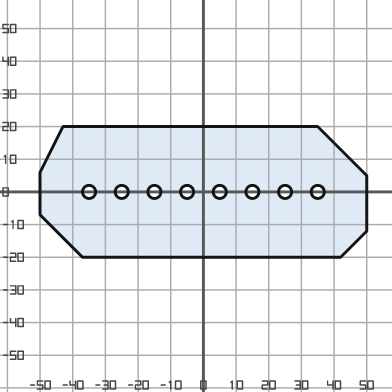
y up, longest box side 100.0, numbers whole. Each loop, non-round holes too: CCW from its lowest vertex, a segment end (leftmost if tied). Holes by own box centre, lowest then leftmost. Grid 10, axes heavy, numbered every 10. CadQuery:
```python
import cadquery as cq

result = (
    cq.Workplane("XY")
    .moveTo(-37.0, -20.0)
    .lineTo(42.0, -20.0)
    .lineTo(50.0, -12.0)
    .lineTo(50.0, 5.0)
    .lineTo(35.0, 20.0)
    .lineTo(-43.0, 20.0)
    .lineTo(-50.0, 6.0)
    .lineTo(-50.0, -7.0)
    .close()
    .moveTo(-35.0, 0.0)
    .circle(2.0)
    .moveTo(-25.0, 0.0)
    .circle(2.0)
    .moveTo(-15.0, 0.0)
    .circle(2.0)
    .moveTo(-5.0, 0.0)
    .circle(2.0)
    .moveTo(5.0, 0.0)
    .circle(2.0)
    .moveTo(15.0, 0.0)
    .circle(2.0)
    .moveTo(25.0, 0.0)
    .circle(2.0)
    .moveTo(35.0, 0.0)
    .circle(2.0)
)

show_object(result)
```